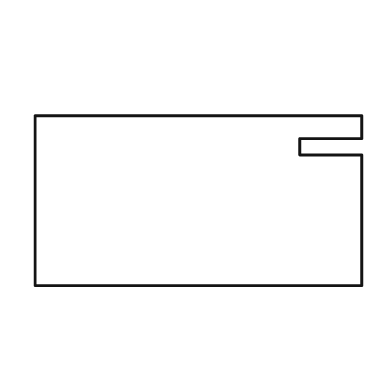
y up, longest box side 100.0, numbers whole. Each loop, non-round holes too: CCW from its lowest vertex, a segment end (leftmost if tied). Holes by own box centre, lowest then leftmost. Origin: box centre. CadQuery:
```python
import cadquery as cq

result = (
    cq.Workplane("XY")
    .moveTo(-50.0, -26.0)
    .lineTo(50.0, -26.0)
    .lineTo(50.0, 14.0)
    .lineTo(31.0, 14.0)
    .lineTo(31.0, 19.0)
    .lineTo(50.0, 19.0)
    .lineTo(50.0, 26.0)
    .lineTo(-50.0, 26.0)
    .close()
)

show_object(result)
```